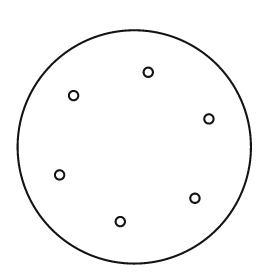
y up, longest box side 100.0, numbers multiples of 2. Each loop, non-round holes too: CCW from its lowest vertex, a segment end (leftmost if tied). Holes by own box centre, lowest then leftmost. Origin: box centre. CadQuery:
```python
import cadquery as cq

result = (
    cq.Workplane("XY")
    .moveTo(0.0, 0.0)
    .circle(50.0)
    .moveTo(-6.0, -32.0)
    .circle(2.0)
    .moveTo(26.0, -22.0)
    .circle(2.0)
    .moveTo(-32.0, -12.0)
    .circle(2.0)
    .moveTo(32.0, 12.0)
    .circle(2.0)
    .moveTo(-26.0, 22.0)
    .circle(2.0)
    .moveTo(6.0, 32.0)
    .circle(2.0)
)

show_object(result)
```